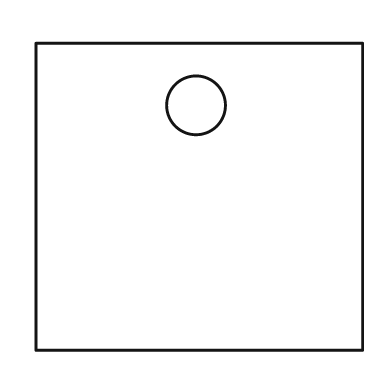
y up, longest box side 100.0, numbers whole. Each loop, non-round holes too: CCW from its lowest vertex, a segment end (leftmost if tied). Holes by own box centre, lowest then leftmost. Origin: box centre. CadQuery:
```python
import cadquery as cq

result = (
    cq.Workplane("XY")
    .moveTo(-50.0, -47.0)
    .lineTo(50.0, -47.0)
    .lineTo(50.0, 47.0)
    .lineTo(-50.0, 47.0)
    .close()
    .moveTo(-1.0, 28.0)
    .circle(9.0)
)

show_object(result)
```